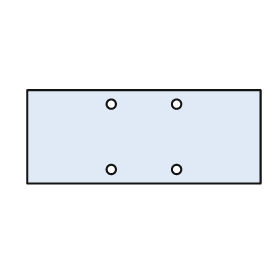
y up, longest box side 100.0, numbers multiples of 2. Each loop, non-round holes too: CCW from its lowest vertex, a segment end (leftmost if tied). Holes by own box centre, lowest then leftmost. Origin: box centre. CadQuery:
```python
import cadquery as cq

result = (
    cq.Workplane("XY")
    .moveTo(-50.0, -20.0)
    .lineTo(50.0, -20.0)
    .lineTo(50.0, 20.0)
    .lineTo(-50.0, 20.0)
    .close()
    .moveTo(-14.0, -14.0)
    .circle(2.0)
    .moveTo(14.0, -14.0)
    .circle(2.0)
    .moveTo(-14.0, 14.0)
    .circle(2.0)
    .moveTo(14.0, 14.0)
    .circle(2.0)
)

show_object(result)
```